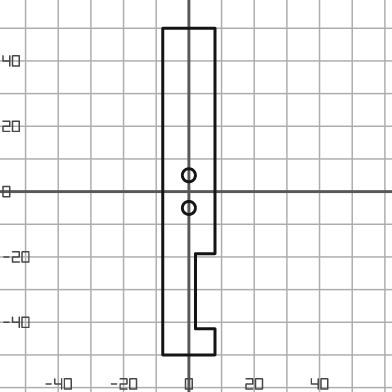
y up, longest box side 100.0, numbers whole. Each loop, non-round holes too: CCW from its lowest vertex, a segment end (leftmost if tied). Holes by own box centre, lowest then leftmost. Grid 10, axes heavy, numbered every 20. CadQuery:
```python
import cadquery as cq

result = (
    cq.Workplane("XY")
    .moveTo(-8.0, -50.0)
    .lineTo(8.0, -50.0)
    .lineTo(8.0, -42.0)
    .lineTo(2.0, -42.0)
    .lineTo(2.0, -19.0)
    .lineTo(8.0, -19.0)
    .lineTo(8.0, 50.0)
    .lineTo(-8.0, 50.0)
    .close()
    .moveTo(0.0, -5.0)
    .circle(2.0)
    .moveTo(0.0, 5.0)
    .circle(2.0)
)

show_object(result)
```